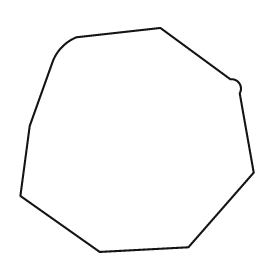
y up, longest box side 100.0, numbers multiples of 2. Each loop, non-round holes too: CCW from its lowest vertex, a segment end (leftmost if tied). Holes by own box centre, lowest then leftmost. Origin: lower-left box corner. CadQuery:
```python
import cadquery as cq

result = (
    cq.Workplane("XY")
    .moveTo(34.0, 0.0)
    .lineTo(72.0, 2.0)
    .lineTo(100.0, 34.0)
    .lineTo(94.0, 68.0)
    .threePointArc((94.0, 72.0), (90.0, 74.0))
    .lineTo(60.0, 96.0)
    .lineTo(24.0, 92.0)
    .threePointArc((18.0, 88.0), (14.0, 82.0))
    .lineTo(4.0, 54.0)
    .lineTo(0.0, 24.0)
    .close()
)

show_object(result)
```